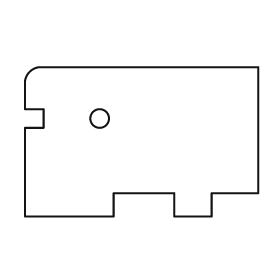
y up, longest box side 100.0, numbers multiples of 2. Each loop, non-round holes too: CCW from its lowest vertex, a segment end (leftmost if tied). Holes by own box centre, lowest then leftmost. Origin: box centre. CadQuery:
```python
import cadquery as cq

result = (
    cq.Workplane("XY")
    .moveTo(-50.0, -32.0)
    .lineTo(-12.0, -32.0)
    .lineTo(-12.0, -22.0)
    .lineTo(14.0, -22.0)
    .lineTo(14.0, -32.0)
    .lineTo(30.0, -32.0)
    .lineTo(30.0, -22.0)
    .lineTo(50.0, -22.0)
    .lineTo(50.0, 32.0)
    .lineTo(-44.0, 32.0)
    .threePointArc((-48.0, 30.0), (-50.0, 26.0))
    .lineTo(-50.0, 14.0)
    .lineTo(-42.0, 14.0)
    .lineTo(-42.0, 6.0)
    .lineTo(-50.0, 6.0)
    .close()
    .moveTo(-18.0, 10.0)
    .circle(4.0)
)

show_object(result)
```